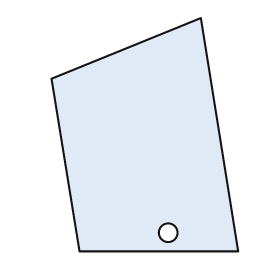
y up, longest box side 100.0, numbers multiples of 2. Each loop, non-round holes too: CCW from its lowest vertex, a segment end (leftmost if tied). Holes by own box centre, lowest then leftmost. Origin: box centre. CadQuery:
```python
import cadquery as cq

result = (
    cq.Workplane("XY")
    .moveTo(-28.0, -50.0)
    .lineTo(40.0, -50.0)
    .lineTo(24.0, 50.0)
    .lineTo(-40.0, 24.0)
    .close()
    .moveTo(10.0, -42.0)
    .circle(4.0)
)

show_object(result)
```